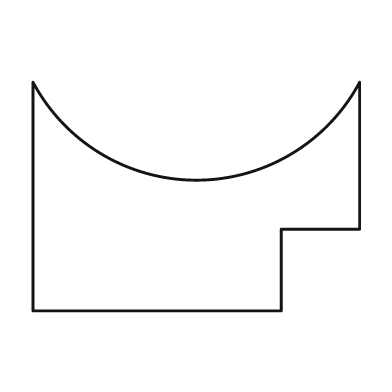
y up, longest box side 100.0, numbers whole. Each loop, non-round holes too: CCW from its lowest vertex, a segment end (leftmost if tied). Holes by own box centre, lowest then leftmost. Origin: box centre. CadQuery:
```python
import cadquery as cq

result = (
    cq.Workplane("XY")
    .moveTo(-50.0, -35.0)
    .lineTo(26.0, -35.0)
    .lineTo(26.0, -10.0)
    .lineTo(50.0, -10.0)
    .lineTo(50.0, 35.0)
    .threePointArc((0.0, 5.0), (-50.0, 35.0))
    .close()
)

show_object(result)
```